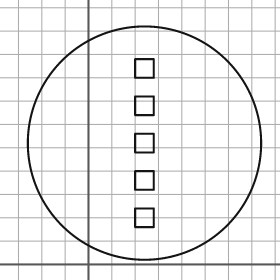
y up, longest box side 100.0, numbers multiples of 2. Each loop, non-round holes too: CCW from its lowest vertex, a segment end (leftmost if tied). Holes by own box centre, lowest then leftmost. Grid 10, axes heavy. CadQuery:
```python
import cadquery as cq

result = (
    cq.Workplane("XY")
    .moveTo(24.0, 52.0)
    .circle(50.0)
    .moveTo(20.0, 16.0)
    .lineTo(28.0, 16.0)
    .lineTo(28.0, 24.0)
    .lineTo(20.0, 24.0)
    .close()
    .moveTo(20.0, 32.0)
    .lineTo(28.0, 32.0)
    .lineTo(28.0, 40.0)
    .lineTo(20.0, 40.0)
    .close()
    .moveTo(20.0, 48.0)
    .lineTo(28.0, 48.0)
    .lineTo(28.0, 56.0)
    .lineTo(20.0, 56.0)
    .close()
    .moveTo(20.0, 64.0)
    .lineTo(28.0, 64.0)
    .lineTo(28.0, 72.0)
    .lineTo(20.0, 72.0)
    .close()
    .moveTo(20.0, 80.0)
    .lineTo(28.0, 80.0)
    .lineTo(28.0, 88.0)
    .lineTo(20.0, 88.0)
    .close()
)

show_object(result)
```